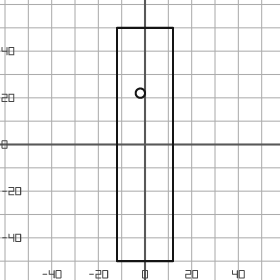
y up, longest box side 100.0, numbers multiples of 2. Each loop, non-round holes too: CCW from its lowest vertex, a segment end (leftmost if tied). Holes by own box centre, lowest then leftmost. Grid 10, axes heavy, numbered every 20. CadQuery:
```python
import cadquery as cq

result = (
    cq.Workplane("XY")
    .moveTo(-12.0, -50.0)
    .lineTo(12.0, -50.0)
    .lineTo(12.0, 50.0)
    .lineTo(-12.0, 50.0)
    .close()
    .moveTo(-2.0, 22.0)
    .circle(2.0)
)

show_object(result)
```